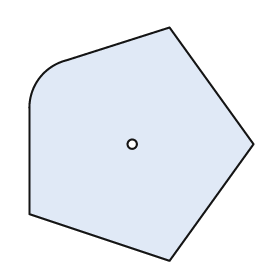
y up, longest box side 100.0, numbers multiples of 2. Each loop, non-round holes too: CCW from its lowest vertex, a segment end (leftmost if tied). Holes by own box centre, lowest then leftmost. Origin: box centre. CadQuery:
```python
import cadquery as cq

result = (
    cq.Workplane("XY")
    .moveTo(12.0, -50.0)
    .lineTo(48.0, 0.0)
    .lineTo(12.0, 50.0)
    .lineTo(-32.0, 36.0)
    .threePointArc((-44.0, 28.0), (-48.0, 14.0))
    .lineTo(-48.0, -30.0)
    .close()
    .moveTo(-4.0, 0.0)
    .circle(2.0)
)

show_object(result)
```